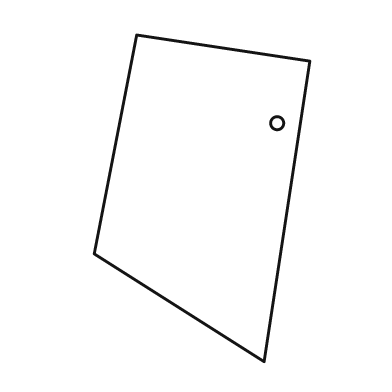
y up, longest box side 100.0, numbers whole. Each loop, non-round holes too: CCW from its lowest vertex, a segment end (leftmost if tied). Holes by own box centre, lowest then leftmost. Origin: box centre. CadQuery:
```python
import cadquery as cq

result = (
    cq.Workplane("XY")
    .moveTo(19.0, -50.0)
    .lineTo(33.0, 42.0)
    .lineTo(-20.0, 50.0)
    .lineTo(-33.0, -17.0)
    .close()
    .moveTo(23.0, 23.0)
    .circle(2.0)
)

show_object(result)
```